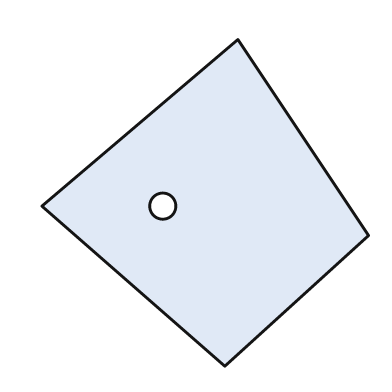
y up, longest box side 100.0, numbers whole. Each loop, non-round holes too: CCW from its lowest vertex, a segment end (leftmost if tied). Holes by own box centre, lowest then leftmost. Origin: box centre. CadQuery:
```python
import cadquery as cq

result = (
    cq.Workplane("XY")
    .moveTo(6.0, -50.0)
    .lineTo(50.0, -10.0)
    .lineTo(10.0, 50.0)
    .lineTo(-50.0, -1.0)
    .close()
    .moveTo(-13.0, -1.0)
    .circle(4.0)
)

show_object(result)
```